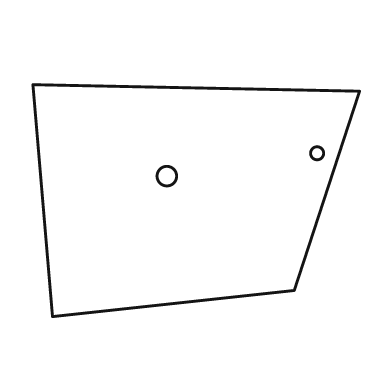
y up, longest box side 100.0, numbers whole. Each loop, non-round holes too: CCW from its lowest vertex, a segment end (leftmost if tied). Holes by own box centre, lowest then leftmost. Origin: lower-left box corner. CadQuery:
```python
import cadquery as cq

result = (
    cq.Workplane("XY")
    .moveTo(6.0, 0.0)
    .lineTo(80.0, 8.0)
    .lineTo(100.0, 69.0)
    .lineTo(0.0, 71.0)
    .close()
    .moveTo(41.0, 43.0)
    .circle(3.0)
    .moveTo(87.0, 50.0)
    .circle(2.0)
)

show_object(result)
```